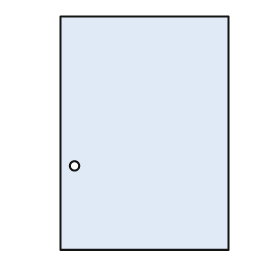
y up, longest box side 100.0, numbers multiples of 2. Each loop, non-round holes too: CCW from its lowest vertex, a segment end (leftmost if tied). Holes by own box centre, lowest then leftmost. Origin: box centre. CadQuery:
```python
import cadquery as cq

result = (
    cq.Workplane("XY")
    .moveTo(-36.0, -50.0)
    .lineTo(36.0, -50.0)
    .lineTo(36.0, 50.0)
    .lineTo(-36.0, 50.0)
    .close()
    .moveTo(-30.0, -14.0)
    .circle(2.0)
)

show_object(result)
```